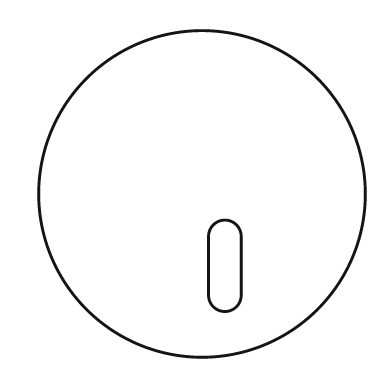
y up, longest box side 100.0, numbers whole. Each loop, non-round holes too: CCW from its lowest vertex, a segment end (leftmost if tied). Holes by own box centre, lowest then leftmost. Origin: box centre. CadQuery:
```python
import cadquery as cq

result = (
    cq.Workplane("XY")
    .moveTo(0.0, 0.0)
    .circle(50.0)
    .moveTo(2.0, -31.0)
    .threePointArc((7.0, -36.0), (12.0, -31.0))
    .lineTo(12.0, -13.0)
    .threePointArc((7.0, -8.0), (2.0, -13.0))
    .close()
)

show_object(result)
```